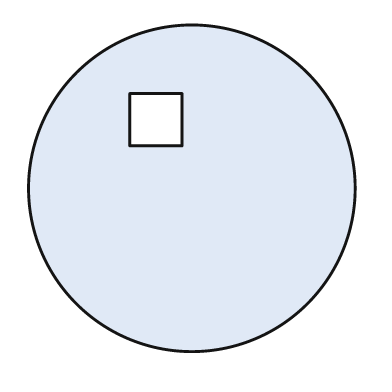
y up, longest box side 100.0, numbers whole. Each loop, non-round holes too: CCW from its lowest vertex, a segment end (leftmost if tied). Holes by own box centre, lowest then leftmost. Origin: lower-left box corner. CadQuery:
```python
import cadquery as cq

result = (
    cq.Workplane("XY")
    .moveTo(50.0, 50.0)
    .circle(50.0)
    .moveTo(31.0, 63.0)
    .lineTo(47.0, 63.0)
    .lineTo(47.0, 79.0)
    .lineTo(31.0, 79.0)
    .close()
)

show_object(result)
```